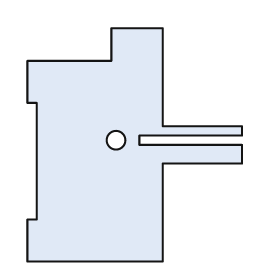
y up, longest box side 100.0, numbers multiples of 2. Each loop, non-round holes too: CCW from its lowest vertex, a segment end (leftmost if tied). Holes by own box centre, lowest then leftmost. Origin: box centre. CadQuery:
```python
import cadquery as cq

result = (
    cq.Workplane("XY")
    .moveTo(-46.0, -50.0)
    .lineTo(12.0, -50.0)
    .lineTo(12.0, -8.0)
    .lineTo(46.0, -8.0)
    .lineTo(46.0, 0.0)
    .lineTo(2.0, 0.0)
    .lineTo(2.0, 4.0)
    .lineTo(46.0, 4.0)
    .lineTo(46.0, 8.0)
    .lineTo(12.0, 8.0)
    .lineTo(12.0, 50.0)
    .lineTo(-10.0, 50.0)
    .lineTo(-10.0, 36.0)
    .lineTo(-46.0, 36.0)
    .lineTo(-46.0, 18.0)
    .lineTo(-42.0, 18.0)
    .lineTo(-42.0, -32.0)
    .lineTo(-46.0, -32.0)
    .close()
    .moveTo(-8.0, 2.0)
    .circle(4.0)
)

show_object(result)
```